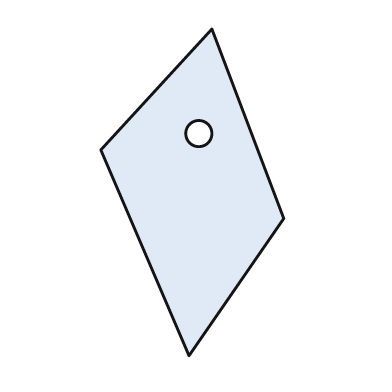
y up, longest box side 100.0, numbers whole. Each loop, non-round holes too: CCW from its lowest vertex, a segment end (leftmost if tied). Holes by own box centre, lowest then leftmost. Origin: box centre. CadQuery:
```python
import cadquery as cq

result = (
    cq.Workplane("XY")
    .moveTo(-1.0, -50.0)
    .lineTo(28.0, -8.0)
    .lineTo(6.0, 50.0)
    .lineTo(-28.0, 13.0)
    .close()
    .moveTo(2.0, 18.0)
    .circle(4.0)
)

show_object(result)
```